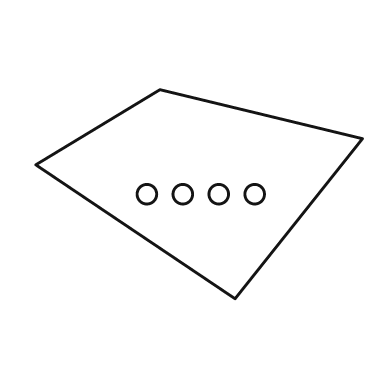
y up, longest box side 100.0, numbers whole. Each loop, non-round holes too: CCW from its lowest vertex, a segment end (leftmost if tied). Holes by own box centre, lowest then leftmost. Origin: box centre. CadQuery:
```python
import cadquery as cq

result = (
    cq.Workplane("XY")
    .moveTo(11.0, -32.0)
    .lineTo(50.0, 17.0)
    .lineTo(-12.0, 32.0)
    .lineTo(-50.0, 9.0)
    .close()
    .moveTo(-16.0, 0.0)
    .circle(3.0)
    .moveTo(-5.0, 0.0)
    .circle(3.0)
    .moveTo(6.0, 0.0)
    .circle(3.0)
    .moveTo(17.0, 0.0)
    .circle(3.0)
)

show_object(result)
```